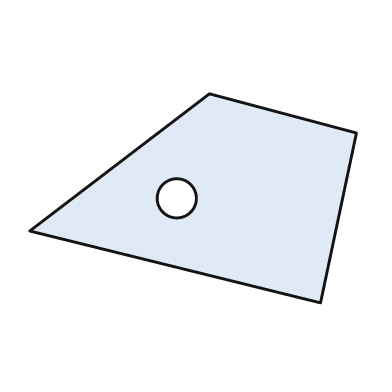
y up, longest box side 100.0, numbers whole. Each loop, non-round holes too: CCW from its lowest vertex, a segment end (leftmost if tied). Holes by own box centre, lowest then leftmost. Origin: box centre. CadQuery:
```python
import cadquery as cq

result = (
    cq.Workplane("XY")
    .moveTo(39.0, -32.0)
    .lineTo(50.0, 20.0)
    .lineTo(5.0, 32.0)
    .lineTo(-50.0, -10.0)
    .close()
    .moveTo(-5.0, 0.0)
    .circle(6.0)
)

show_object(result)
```